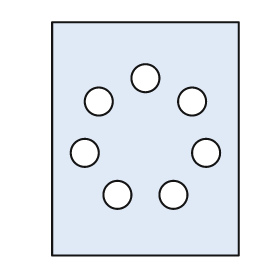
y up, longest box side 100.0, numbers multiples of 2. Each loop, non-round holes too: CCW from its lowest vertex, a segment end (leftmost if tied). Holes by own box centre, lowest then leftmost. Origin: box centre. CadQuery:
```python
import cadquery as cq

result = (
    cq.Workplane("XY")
    .moveTo(-40.0, -50.0)
    .lineTo(40.0, -50.0)
    .lineTo(40.0, 50.0)
    .lineTo(-40.0, 50.0)
    .close()
    .moveTo(-12.0, -24.0)
    .circle(6.0)
    .moveTo(12.0, -24.0)
    .circle(6.0)
    .moveTo(-26.0, -6.0)
    .circle(6.0)
    .moveTo(26.0, -6.0)
    .circle(6.0)
    .moveTo(-20.0, 16.0)
    .circle(6.0)
    .moveTo(20.0, 16.0)
    .circle(6.0)
    .moveTo(0.0, 26.0)
    .circle(6.0)
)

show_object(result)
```